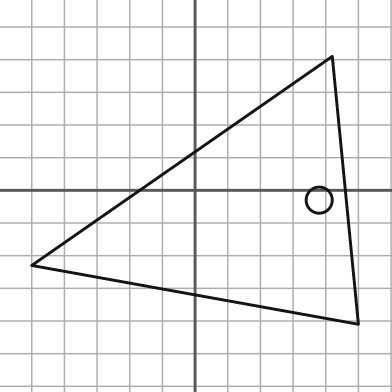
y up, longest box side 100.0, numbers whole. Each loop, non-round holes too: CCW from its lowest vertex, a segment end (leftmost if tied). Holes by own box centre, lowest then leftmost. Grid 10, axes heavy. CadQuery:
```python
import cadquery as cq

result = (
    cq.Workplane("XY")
    .moveTo(50.0, -41.0)
    .lineTo(42.0, 41.0)
    .lineTo(-50.0, -23.0)
    .close()
    .moveTo(38.0, -3.0)
    .circle(4.0)
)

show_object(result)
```